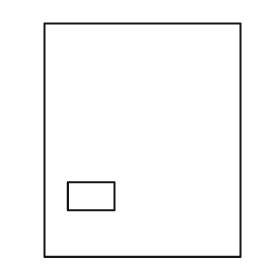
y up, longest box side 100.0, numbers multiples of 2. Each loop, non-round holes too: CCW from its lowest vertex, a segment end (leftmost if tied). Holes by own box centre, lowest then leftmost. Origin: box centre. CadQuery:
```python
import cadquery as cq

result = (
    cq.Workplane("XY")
    .moveTo(-42.0, -50.0)
    .lineTo(42.0, -50.0)
    .lineTo(42.0, 50.0)
    .lineTo(-42.0, 50.0)
    .close()
    .moveTo(-32.0, -30.0)
    .lineTo(-12.0, -30.0)
    .lineTo(-12.0, -18.0)
    .lineTo(-32.0, -18.0)
    .close()
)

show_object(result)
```